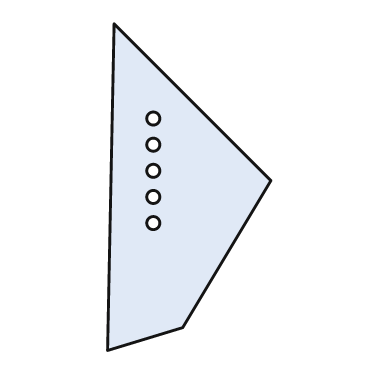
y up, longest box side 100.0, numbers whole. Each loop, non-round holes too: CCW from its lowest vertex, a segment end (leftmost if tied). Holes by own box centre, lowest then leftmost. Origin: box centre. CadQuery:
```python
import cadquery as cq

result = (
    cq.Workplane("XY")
    .moveTo(-25.0, -50.0)
    .lineTo(-2.0, -43.0)
    .lineTo(25.0, 2.0)
    .lineTo(-23.0, 50.0)
    .close()
    .moveTo(-11.0, -11.0)
    .circle(2.0)
    .moveTo(-11.0, -3.0)
    .circle(2.0)
    .moveTo(-11.0, 5.0)
    .circle(2.0)
    .moveTo(-11.0, 13.0)
    .circle(2.0)
    .moveTo(-11.0, 21.0)
    .circle(2.0)
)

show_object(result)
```